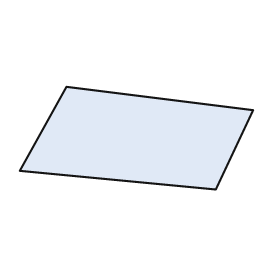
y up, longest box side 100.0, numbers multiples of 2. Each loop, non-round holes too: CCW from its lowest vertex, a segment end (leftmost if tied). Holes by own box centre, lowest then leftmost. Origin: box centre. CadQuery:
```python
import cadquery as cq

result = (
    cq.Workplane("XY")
    .moveTo(34.0, -22.0)
    .lineTo(50.0, 12.0)
    .lineTo(-30.0, 22.0)
    .lineTo(-50.0, -14.0)
    .close()
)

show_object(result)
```